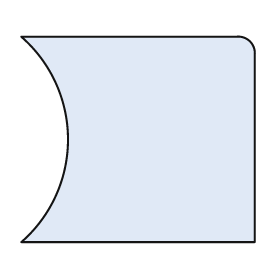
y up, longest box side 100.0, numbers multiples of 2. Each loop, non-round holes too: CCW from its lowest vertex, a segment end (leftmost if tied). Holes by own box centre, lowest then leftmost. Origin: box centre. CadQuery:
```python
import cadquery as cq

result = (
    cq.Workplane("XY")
    .moveTo(-50.0, -44.0)
    .lineTo(50.0, -44.0)
    .lineTo(50.0, 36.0)
    .threePointArc((48.0, 42.0), (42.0, 44.0))
    .lineTo(-50.0, 44.0)
    .threePointArc((-30.0, 0.0), (-50.0, -44.0))
    .close()
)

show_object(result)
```